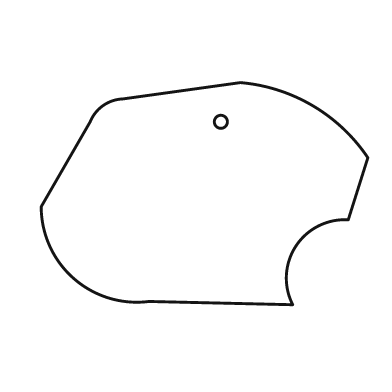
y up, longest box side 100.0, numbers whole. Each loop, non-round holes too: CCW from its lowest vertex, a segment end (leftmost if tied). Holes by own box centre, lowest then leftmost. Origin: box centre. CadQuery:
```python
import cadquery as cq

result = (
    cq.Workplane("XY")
    .moveTo(27.0, -34.0)
    .threePointArc((28.0, -16.0), (44.0, -8.0))
    .lineTo(50.0, 11.0)
    .threePointArc((33.0, 27.0), (11.0, 34.0))
    .lineTo(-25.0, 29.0)
    .threePointArc((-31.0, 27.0), (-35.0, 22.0))
    .lineTo(-50.0, -4.0)
    .threePointArc((-40.0, -26.0), (-17.0, -33.0))
    .close()
    .moveTo(5.0, 22.0)
    .circle(2.0)
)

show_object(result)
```